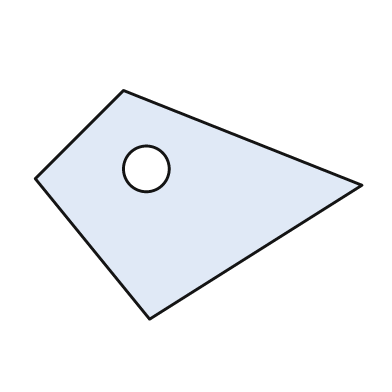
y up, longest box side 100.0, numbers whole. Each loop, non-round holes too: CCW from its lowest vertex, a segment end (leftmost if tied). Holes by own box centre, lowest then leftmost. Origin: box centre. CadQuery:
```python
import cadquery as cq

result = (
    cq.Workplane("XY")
    .moveTo(-15.0, -35.0)
    .lineTo(50.0, 6.0)
    .lineTo(-23.0, 35.0)
    .lineTo(-50.0, 8.0)
    .close()
    .moveTo(-16.0, 11.0)
    .circle(7.0)
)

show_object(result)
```